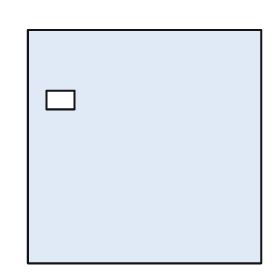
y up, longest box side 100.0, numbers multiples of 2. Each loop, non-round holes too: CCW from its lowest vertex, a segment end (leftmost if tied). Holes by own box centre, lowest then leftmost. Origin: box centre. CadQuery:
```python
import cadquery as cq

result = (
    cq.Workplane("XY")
    .moveTo(-50.0, -50.0)
    .lineTo(50.0, -50.0)
    .lineTo(50.0, 50.0)
    .lineTo(-50.0, 50.0)
    .close()
    .moveTo(-42.0, 16.0)
    .lineTo(-30.0, 16.0)
    .lineTo(-30.0, 24.0)
    .lineTo(-42.0, 24.0)
    .close()
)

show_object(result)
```